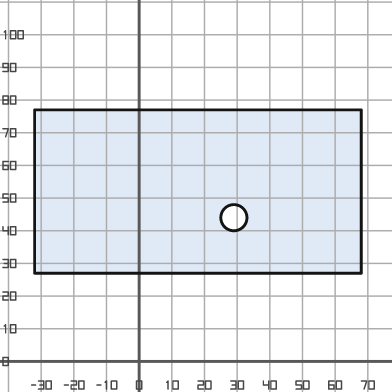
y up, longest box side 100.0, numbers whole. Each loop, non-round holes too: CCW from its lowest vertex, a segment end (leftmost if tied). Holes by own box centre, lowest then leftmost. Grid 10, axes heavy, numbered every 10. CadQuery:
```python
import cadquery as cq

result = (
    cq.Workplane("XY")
    .moveTo(-32.0, 27.0)
    .lineTo(68.0, 27.0)
    .lineTo(68.0, 77.0)
    .lineTo(-32.0, 77.0)
    .close()
    .moveTo(29.0, 44.0)
    .circle(4.0)
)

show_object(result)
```